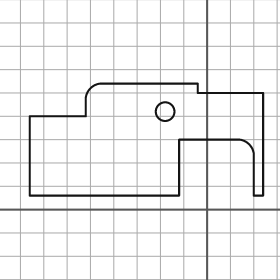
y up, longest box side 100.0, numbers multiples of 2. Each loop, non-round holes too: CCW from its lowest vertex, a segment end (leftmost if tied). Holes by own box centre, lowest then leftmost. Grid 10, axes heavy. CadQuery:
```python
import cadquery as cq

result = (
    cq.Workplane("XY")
    .moveTo(-76.0, 6.0)
    .lineTo(-12.0, 6.0)
    .lineTo(-12.0, 30.0)
    .lineTo(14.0, 30.0)
    .threePointArc((18.0, 28.0), (20.0, 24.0))
    .lineTo(20.0, 6.0)
    .lineTo(24.0, 6.0)
    .lineTo(24.0, 50.0)
    .lineTo(-4.0, 50.0)
    .lineTo(-4.0, 54.0)
    .lineTo(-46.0, 54.0)
    .threePointArc((-50.0, 52.0), (-52.0, 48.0))
    .lineTo(-52.0, 40.0)
    .lineTo(-76.0, 40.0)
    .close()
    .moveTo(-18.0, 42.0)
    .circle(4.0)
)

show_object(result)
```